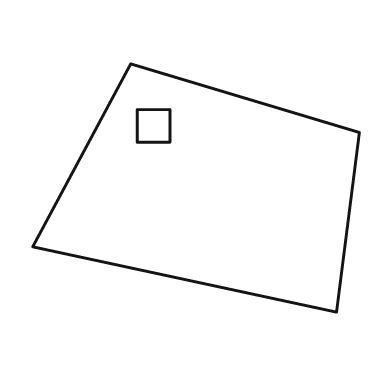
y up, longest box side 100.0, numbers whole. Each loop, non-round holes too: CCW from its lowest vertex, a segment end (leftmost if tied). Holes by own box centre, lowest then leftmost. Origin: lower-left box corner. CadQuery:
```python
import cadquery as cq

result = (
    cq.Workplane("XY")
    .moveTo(93.0, 0.0)
    .lineTo(100.0, 55.0)
    .lineTo(30.0, 76.0)
    .lineTo(0.0, 20.0)
    .close()
    .moveTo(32.0, 52.0)
    .lineTo(42.0, 52.0)
    .lineTo(42.0, 62.0)
    .lineTo(32.0, 62.0)
    .close()
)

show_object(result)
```